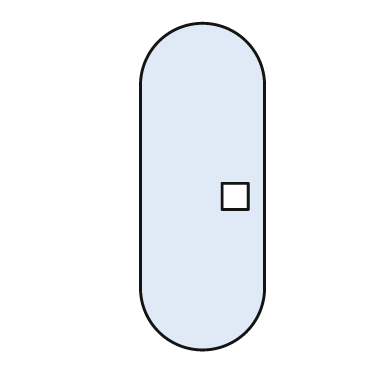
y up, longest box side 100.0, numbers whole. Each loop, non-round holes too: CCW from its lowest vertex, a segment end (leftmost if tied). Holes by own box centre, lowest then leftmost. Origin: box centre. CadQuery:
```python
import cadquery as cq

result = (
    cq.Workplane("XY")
    .moveTo(-19.0, -31.0)
    .threePointArc((0.0, -50.0), (19.0, -31.0))
    .lineTo(19.0, 31.0)
    .threePointArc((0.0, 50.0), (-19.0, 31.0))
    .close()
    .moveTo(6.0, -7.0)
    .lineTo(14.0, -7.0)
    .lineTo(14.0, 1.0)
    .lineTo(6.0, 1.0)
    .close()
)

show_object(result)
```